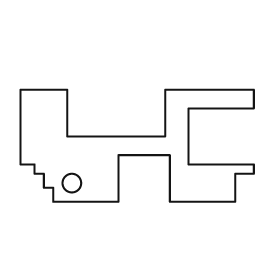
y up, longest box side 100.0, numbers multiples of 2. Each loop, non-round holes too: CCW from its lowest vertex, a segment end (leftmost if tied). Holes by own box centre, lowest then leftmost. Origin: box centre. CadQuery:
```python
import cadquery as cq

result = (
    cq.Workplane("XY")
    .moveTo(-36.0, -24.0)
    .lineTo(-8.0, -24.0)
    .lineTo(-8.0, -4.0)
    .lineTo(14.0, -4.0)
    .lineTo(14.0, -24.0)
    .lineTo(42.0, -24.0)
    .lineTo(42.0, -12.0)
    .lineTo(50.0, -12.0)
    .lineTo(50.0, -8.0)
    .lineTo(22.0, -8.0)
    .lineTo(22.0, 16.0)
    .lineTo(50.0, 16.0)
    .lineTo(50.0, 24.0)
    .lineTo(12.0, 24.0)
    .lineTo(12.0, 4.0)
    .lineTo(-30.0, 4.0)
    .lineTo(-30.0, 24.0)
    .lineTo(-50.0, 24.0)
    .lineTo(-50.0, -8.0)
    .lineTo(-44.0, -8.0)
    .lineTo(-44.0, -12.0)
    .lineTo(-40.0, -12.0)
    .lineTo(-40.0, -18.0)
    .lineTo(-36.0, -18.0)
    .close()
    .moveTo(-28.0, -16.0)
    .circle(4.0)
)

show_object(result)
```